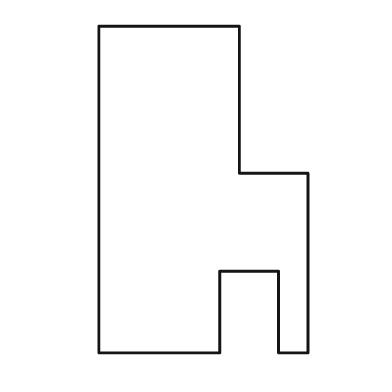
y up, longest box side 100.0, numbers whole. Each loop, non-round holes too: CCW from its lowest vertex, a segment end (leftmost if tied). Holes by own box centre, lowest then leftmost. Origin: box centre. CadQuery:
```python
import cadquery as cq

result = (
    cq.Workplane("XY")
    .moveTo(-32.0, -50.0)
    .lineTo(5.0, -50.0)
    .lineTo(5.0, -25.0)
    .lineTo(23.0, -25.0)
    .lineTo(23.0, -50.0)
    .lineTo(32.0, -50.0)
    .lineTo(32.0, 5.0)
    .lineTo(11.0, 5.0)
    .lineTo(11.0, 50.0)
    .lineTo(-32.0, 50.0)
    .close()
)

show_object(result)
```